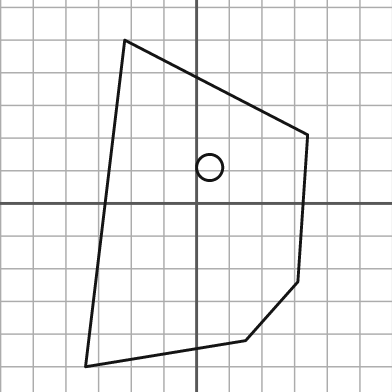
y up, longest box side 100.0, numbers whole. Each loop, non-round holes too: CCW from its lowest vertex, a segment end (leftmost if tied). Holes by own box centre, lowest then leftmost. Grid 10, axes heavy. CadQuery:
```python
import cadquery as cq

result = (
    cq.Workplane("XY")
    .moveTo(-34.0, -50.0)
    .lineTo(15.0, -42.0)
    .lineTo(31.0, -24.0)
    .lineTo(34.0, 21.0)
    .lineTo(-22.0, 50.0)
    .close()
    .moveTo(4.0, 11.0)
    .circle(4.0)
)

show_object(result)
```